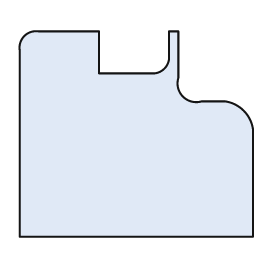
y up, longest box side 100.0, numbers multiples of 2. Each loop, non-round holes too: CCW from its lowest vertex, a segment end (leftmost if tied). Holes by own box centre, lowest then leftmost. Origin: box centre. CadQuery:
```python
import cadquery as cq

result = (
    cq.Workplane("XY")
    .moveTo(-50.0, -44.0)
    .lineTo(50.0, -44.0)
    .lineTo(50.0, 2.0)
    .threePointArc((46.0, 10.0), (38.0, 14.0))
    .lineTo(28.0, 14.0)
    .threePointArc((20.0, 16.0), (18.0, 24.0))
    .lineTo(18.0, 44.0)
    .lineTo(14.0, 44.0)
    .lineTo(14.0, 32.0)
    .threePointArc((12.0, 28.0), (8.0, 26.0))
    .lineTo(-16.0, 26.0)
    .lineTo(-16.0, 44.0)
    .lineTo(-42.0, 44.0)
    .threePointArc((-48.0, 42.0), (-50.0, 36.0))
    .close()
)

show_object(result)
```